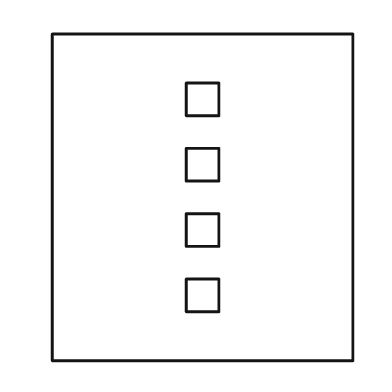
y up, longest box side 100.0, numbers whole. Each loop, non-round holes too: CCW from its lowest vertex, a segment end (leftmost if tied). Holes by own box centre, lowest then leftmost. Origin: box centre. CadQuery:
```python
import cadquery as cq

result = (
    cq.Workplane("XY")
    .moveTo(-46.0, -50.0)
    .lineTo(46.0, -50.0)
    .lineTo(46.0, 50.0)
    .lineTo(-46.0, 50.0)
    .close()
    .moveTo(-5.0, -35.0)
    .lineTo(5.0, -35.0)
    .lineTo(5.0, -25.0)
    .lineTo(-5.0, -25.0)
    .close()
    .moveTo(-5.0, -15.0)
    .lineTo(5.0, -15.0)
    .lineTo(5.0, -5.0)
    .lineTo(-5.0, -5.0)
    .close()
    .moveTo(-5.0, 5.0)
    .lineTo(5.0, 5.0)
    .lineTo(5.0, 15.0)
    .lineTo(-5.0, 15.0)
    .close()
    .moveTo(-5.0, 25.0)
    .lineTo(5.0, 25.0)
    .lineTo(5.0, 35.0)
    .lineTo(-5.0, 35.0)
    .close()
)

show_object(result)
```